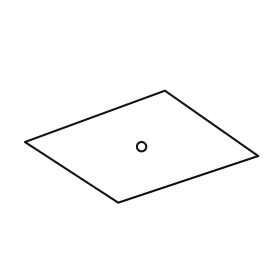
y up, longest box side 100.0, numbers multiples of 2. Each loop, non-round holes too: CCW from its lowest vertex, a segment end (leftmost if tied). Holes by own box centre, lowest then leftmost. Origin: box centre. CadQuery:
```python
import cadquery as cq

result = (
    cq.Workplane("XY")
    .moveTo(-10.0, -24.0)
    .lineTo(50.0, -4.0)
    .lineTo(10.0, 24.0)
    .lineTo(-50.0, 2.0)
    .close()
    .moveTo(0.0, 0.0)
    .circle(2.0)
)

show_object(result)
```